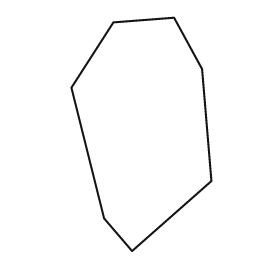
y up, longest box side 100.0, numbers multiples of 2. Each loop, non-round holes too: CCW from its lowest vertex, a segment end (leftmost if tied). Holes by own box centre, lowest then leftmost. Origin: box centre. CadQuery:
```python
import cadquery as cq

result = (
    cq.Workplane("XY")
    .moveTo(-4.0, -50.0)
    .lineTo(30.0, -20.0)
    .lineTo(26.0, 28.0)
    .lineTo(14.0, 50.0)
    .lineTo(-12.0, 48.0)
    .lineTo(-30.0, 20.0)
    .lineTo(-16.0, -36.0)
    .close()
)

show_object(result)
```